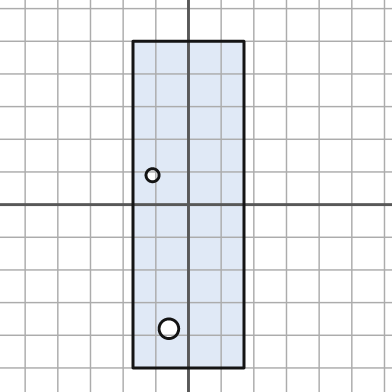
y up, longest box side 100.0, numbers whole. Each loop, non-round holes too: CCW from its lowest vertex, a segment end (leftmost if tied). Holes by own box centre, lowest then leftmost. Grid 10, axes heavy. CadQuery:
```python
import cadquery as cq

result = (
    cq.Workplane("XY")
    .moveTo(-17.0, -50.0)
    .lineTo(17.0, -50.0)
    .lineTo(17.0, 50.0)
    .lineTo(-17.0, 50.0)
    .close()
    .moveTo(-6.0, -38.0)
    .circle(3.0)
    .moveTo(-11.0, 9.0)
    .circle(2.0)
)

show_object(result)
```